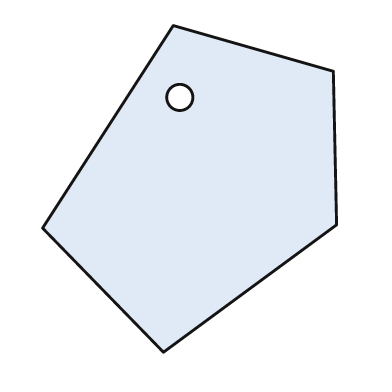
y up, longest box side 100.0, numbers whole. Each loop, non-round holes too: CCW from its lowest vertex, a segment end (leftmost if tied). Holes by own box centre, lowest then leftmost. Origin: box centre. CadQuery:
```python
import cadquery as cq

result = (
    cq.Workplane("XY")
    .moveTo(-8.0, -50.0)
    .lineTo(45.0, -11.0)
    .lineTo(44.0, 36.0)
    .lineTo(-5.0, 50.0)
    .lineTo(-45.0, -12.0)
    .close()
    .moveTo(-3.0, 28.0)
    .circle(4.0)
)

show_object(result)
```